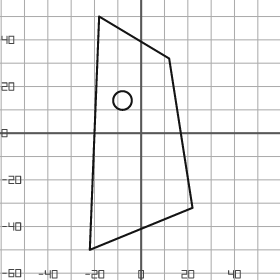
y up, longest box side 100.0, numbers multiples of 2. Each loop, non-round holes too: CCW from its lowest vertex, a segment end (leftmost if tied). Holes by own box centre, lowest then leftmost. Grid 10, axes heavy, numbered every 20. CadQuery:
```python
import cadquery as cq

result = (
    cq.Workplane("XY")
    .moveTo(-22.0, -50.0)
    .lineTo(22.0, -32.0)
    .lineTo(12.0, 32.0)
    .lineTo(-18.0, 50.0)
    .close()
    .moveTo(-8.0, 14.0)
    .circle(4.0)
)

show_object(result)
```